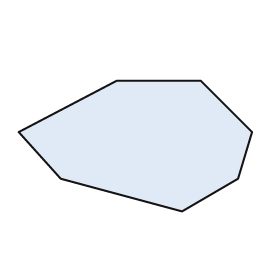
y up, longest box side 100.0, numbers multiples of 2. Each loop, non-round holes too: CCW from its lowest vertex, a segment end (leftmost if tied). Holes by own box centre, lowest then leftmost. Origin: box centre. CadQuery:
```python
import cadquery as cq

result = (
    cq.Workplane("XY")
    .moveTo(20.0, -28.0)
    .lineTo(44.0, -14.0)
    .lineTo(50.0, 6.0)
    .lineTo(28.0, 28.0)
    .lineTo(-8.0, 28.0)
    .lineTo(-50.0, 6.0)
    .lineTo(-32.0, -14.0)
    .close()
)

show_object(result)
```